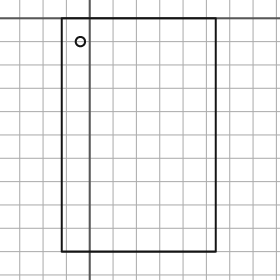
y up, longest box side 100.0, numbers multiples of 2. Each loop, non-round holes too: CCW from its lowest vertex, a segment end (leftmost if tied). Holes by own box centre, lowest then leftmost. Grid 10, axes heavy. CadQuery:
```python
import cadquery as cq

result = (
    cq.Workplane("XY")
    .moveTo(-12.0, -100.0)
    .lineTo(54.0, -100.0)
    .lineTo(54.0, 0.0)
    .lineTo(-12.0, 0.0)
    .close()
    .moveTo(-4.0, -10.0)
    .circle(2.0)
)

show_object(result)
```